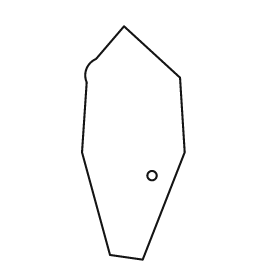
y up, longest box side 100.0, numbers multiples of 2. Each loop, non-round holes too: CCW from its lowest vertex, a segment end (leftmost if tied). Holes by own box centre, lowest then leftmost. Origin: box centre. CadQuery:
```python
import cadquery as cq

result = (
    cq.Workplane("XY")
    .moveTo(4.0, -50.0)
    .lineTo(22.0, -4.0)
    .lineTo(20.0, 28.0)
    .lineTo(-4.0, 50.0)
    .lineTo(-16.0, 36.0)
    .threePointArc((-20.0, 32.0), (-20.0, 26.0))
    .lineTo(-22.0, -4.0)
    .lineTo(-10.0, -48.0)
    .close()
    .moveTo(8.0, -14.0)
    .circle(2.0)
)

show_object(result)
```